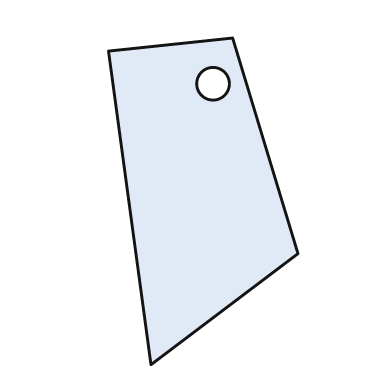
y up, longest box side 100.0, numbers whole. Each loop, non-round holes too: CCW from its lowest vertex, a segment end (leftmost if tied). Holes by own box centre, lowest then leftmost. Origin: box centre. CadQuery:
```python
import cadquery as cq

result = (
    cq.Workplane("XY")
    .moveTo(-16.0, -50.0)
    .lineTo(29.0, -16.0)
    .lineTo(9.0, 50.0)
    .lineTo(-29.0, 46.0)
    .close()
    .moveTo(3.0, 36.0)
    .circle(5.0)
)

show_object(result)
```